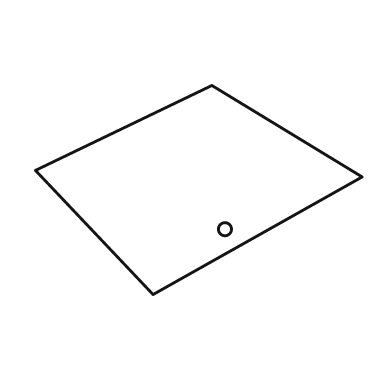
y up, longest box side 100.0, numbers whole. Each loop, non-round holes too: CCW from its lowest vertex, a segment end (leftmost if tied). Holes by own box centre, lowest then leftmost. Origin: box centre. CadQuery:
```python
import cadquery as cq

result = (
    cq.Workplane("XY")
    .moveTo(-14.0, -32.0)
    .lineTo(50.0, 4.0)
    .lineTo(4.0, 32.0)
    .lineTo(-50.0, 6.0)
    .close()
    .moveTo(8.0, -12.0)
    .circle(2.0)
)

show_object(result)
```